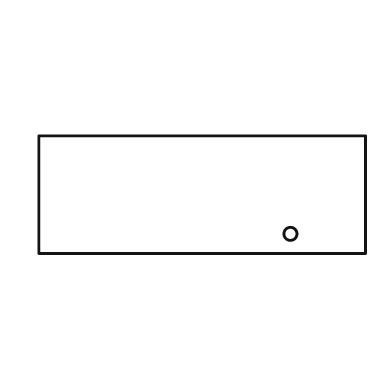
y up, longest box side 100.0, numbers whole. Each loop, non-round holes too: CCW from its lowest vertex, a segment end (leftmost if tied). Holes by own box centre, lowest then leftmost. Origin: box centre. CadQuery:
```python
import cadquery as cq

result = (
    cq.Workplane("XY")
    .moveTo(-50.0, -18.0)
    .lineTo(50.0, -18.0)
    .lineTo(50.0, 18.0)
    .lineTo(-50.0, 18.0)
    .close()
    .moveTo(27.0, -12.0)
    .circle(2.0)
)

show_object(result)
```